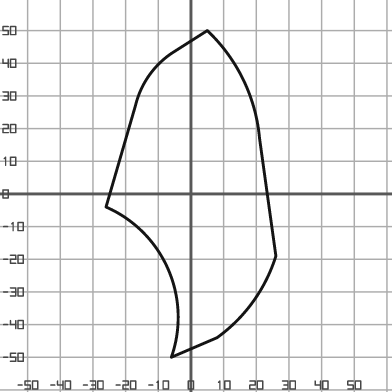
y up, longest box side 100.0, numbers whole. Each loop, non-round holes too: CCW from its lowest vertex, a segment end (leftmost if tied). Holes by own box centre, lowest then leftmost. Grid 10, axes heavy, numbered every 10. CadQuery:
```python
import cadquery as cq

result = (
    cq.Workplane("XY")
    .moveTo(-6.0, -50.0)
    .lineTo(8.0, -44.0)
    .threePointArc((19.0, -33.0), (26.0, -19.0))
    .lineTo(21.0, 17.0)
    .threePointArc((16.0, 35.0), (5.0, 50.0))
    .lineTo(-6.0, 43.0)
    .threePointArc((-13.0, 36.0), (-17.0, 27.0))
    .lineTo(-26.0, -4.0)
    .threePointArc((-7.0, -23.0), (-6.0, -50.0))
    .close()
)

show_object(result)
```